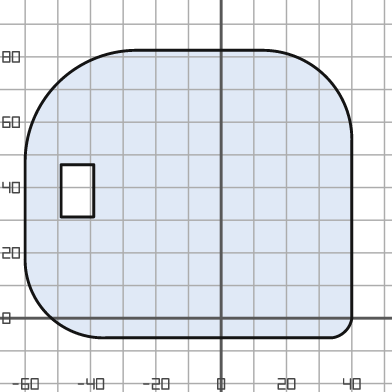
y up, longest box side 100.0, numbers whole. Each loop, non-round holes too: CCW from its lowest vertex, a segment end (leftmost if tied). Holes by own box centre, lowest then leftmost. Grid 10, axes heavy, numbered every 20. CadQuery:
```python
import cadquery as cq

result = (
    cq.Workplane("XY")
    .moveTo(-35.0, -6.0)
    .lineTo(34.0, -6.0)
    .threePointArc((38.0, -4.0), (40.0, 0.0))
    .lineTo(40.0, 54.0)
    .threePointArc((32.0, 74.0), (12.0, 82.0))
    .lineTo(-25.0, 82.0)
    .threePointArc((-50.0, 72.0), (-60.0, 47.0))
    .lineTo(-60.0, 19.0)
    .threePointArc((-53.0, 1.0), (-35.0, -6.0))
    .close()
    .moveTo(-49.0, 31.0)
    .lineTo(-39.0, 31.0)
    .lineTo(-39.0, 47.0)
    .lineTo(-49.0, 47.0)
    .close()
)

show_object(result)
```